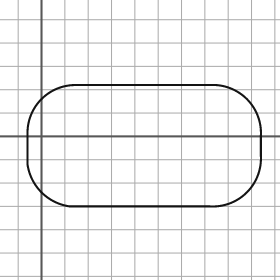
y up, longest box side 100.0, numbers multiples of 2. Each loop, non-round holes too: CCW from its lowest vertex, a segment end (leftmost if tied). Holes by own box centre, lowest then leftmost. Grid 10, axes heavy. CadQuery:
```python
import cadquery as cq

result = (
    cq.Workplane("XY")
    .moveTo(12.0, -30.0)
    .lineTo(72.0, -30.0)
    .threePointArc((88.0, -24.0), (94.0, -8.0))
    .lineTo(94.0, 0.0)
    .threePointArc((88.0, 16.0), (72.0, 22.0))
    .lineTo(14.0, 22.0)
    .threePointArc((0.0, 16.0), (-6.0, 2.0))
    .lineTo(-6.0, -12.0)
    .threePointArc((0.0, -24.0), (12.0, -30.0))
    .close()
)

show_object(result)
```